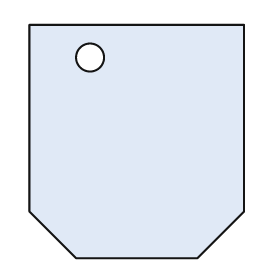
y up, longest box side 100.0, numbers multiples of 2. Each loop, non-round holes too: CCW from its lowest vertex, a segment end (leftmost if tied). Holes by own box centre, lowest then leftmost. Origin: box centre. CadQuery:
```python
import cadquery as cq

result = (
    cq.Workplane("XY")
    .moveTo(-26.0, -50.0)
    .lineTo(26.0, -50.0)
    .lineTo(46.0, -30.0)
    .lineTo(46.0, 50.0)
    .lineTo(-46.0, 50.0)
    .lineTo(-46.0, -30.0)
    .close()
    .moveTo(-20.0, 36.0)
    .circle(6.0)
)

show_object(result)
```